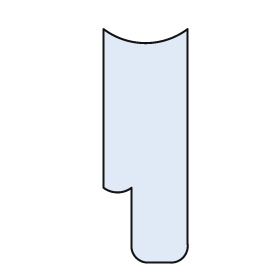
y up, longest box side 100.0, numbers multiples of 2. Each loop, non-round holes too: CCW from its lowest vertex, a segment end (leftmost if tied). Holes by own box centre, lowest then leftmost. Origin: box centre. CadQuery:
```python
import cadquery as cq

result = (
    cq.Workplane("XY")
    .moveTo(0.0, -50.0)
    .lineTo(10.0, -50.0)
    .threePointArc((16.0, -48.0), (18.0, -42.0))
    .lineTo(18.0, 50.0)
    .threePointArc((0.0, 44.0), (-18.0, 50.0))
    .lineTo(-18.0, -18.0)
    .threePointArc((-12.0, -20.0), (-6.0, -18.0))
    .lineTo(-6.0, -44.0)
    .threePointArc((-4.0, -48.0), (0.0, -50.0))
    .close()
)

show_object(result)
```